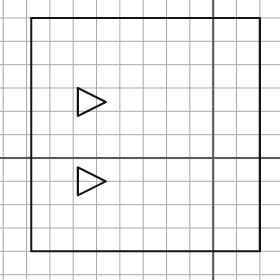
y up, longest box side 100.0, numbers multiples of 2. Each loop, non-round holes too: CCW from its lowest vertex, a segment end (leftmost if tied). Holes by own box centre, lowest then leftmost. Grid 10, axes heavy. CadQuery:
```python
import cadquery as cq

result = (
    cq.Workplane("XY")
    .moveTo(-78.0, -40.0)
    .lineTo(20.0, -40.0)
    .lineTo(20.0, 60.0)
    .lineTo(-78.0, 60.0)
    .close()
    .moveTo(-58.0, -16.0)
    .lineTo(-46.0, -10.0)
    .lineTo(-58.0, -4.0)
    .close()
    .moveTo(-58.0, 18.0)
    .lineTo(-46.0, 24.0)
    .lineTo(-58.0, 30.0)
    .close()
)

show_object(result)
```